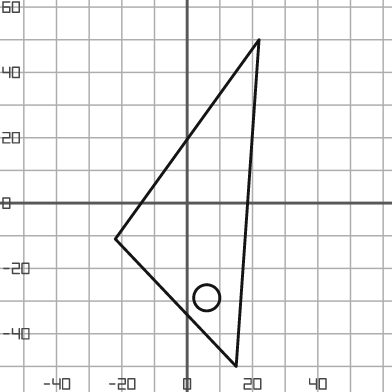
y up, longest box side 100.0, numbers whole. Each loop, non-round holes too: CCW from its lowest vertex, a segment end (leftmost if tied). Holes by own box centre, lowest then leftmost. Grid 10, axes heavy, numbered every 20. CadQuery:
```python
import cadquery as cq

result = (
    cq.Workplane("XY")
    .moveTo(15.0, -50.0)
    .lineTo(22.0, 50.0)
    .lineTo(-22.0, -11.0)
    .close()
    .moveTo(6.0, -29.0)
    .circle(4.0)
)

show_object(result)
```